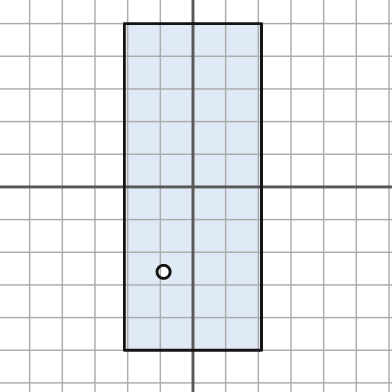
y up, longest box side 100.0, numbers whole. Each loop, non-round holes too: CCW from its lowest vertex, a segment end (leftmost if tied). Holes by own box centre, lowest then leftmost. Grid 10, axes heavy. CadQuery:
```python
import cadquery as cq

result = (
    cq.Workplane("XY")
    .moveTo(-21.0, -50.0)
    .lineTo(21.0, -50.0)
    .lineTo(21.0, 50.0)
    .lineTo(-21.0, 50.0)
    .close()
    .moveTo(-9.0, -26.0)
    .circle(2.0)
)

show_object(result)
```